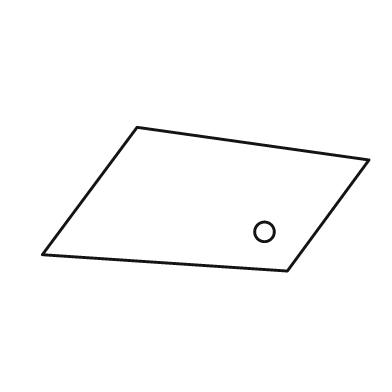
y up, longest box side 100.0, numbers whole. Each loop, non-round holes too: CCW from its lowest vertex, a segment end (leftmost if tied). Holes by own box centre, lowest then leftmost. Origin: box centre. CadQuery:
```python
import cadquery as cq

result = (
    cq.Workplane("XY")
    .moveTo(25.0, -22.0)
    .lineTo(50.0, 12.0)
    .lineTo(-21.0, 22.0)
    .lineTo(-50.0, -17.0)
    .close()
    .moveTo(18.0, -10.0)
    .circle(3.0)
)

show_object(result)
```